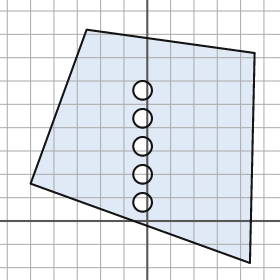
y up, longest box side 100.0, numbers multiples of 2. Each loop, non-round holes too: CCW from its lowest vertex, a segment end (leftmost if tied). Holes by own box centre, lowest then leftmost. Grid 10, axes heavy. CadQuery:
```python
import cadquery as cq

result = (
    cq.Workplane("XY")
    .moveTo(44.0, -18.0)
    .lineTo(46.0, 72.0)
    .lineTo(-26.0, 82.0)
    .lineTo(-50.0, 16.0)
    .close()
    .moveTo(-2.0, 8.0)
    .circle(4.0)
    .moveTo(-2.0, 20.0)
    .circle(4.0)
    .moveTo(-2.0, 32.0)
    .circle(4.0)
    .moveTo(-2.0, 44.0)
    .circle(4.0)
    .moveTo(-2.0, 56.0)
    .circle(4.0)
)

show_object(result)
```